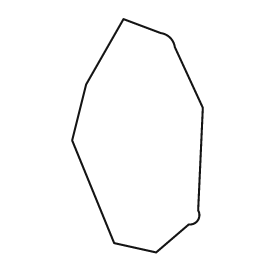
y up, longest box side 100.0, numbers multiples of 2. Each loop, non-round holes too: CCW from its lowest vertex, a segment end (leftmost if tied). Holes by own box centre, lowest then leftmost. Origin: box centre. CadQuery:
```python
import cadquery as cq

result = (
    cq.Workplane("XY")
    .moveTo(8.0, -50.0)
    .lineTo(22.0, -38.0)
    .threePointArc((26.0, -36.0), (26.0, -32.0))
    .lineTo(28.0, 12.0)
    .lineTo(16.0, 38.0)
    .threePointArc((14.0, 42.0), (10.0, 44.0))
    .lineTo(-6.0, 50.0)
    .lineTo(-22.0, 22.0)
    .lineTo(-28.0, -2.0)
    .lineTo(-10.0, -46.0)
    .close()
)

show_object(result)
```